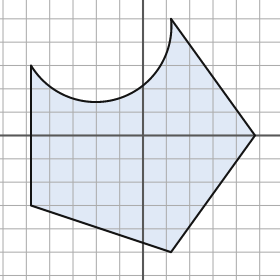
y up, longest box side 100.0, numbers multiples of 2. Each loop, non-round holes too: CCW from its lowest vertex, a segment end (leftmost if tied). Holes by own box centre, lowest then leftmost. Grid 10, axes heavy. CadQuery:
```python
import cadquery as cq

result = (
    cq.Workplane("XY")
    .moveTo(12.0, -50.0)
    .lineTo(48.0, 0.0)
    .lineTo(12.0, 50.0)
    .threePointArc((-10.0, 16.0), (-48.0, 30.0))
    .lineTo(-48.0, -30.0)
    .close()
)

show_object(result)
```